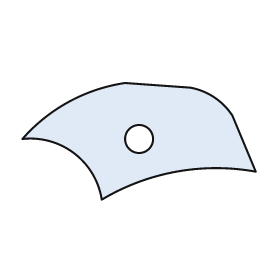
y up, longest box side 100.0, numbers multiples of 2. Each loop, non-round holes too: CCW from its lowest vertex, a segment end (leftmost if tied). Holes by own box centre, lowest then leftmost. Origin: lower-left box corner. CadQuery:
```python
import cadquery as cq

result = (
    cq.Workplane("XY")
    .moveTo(34.0, 0.0)
    .threePointArc((66.0, 12.0), (100.0, 12.0))
    .lineTo(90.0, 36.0)
    .threePointArc((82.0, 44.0), (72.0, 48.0))
    .lineTo(44.0, 50.0)
    .threePointArc((20.0, 42.0), (0.0, 26.0))
    .threePointArc((22.0, 20.0), (34.0, 0.0))
    .close()
    .moveTo(50.0, 26.0)
    .circle(6.0)
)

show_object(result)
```